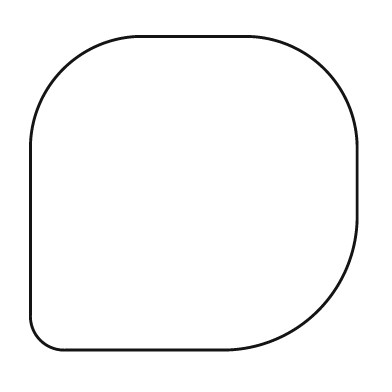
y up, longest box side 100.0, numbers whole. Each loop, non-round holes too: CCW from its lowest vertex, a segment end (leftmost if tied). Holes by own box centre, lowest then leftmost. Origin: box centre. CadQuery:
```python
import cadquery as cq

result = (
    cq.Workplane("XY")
    .moveTo(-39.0, -48.0)
    .lineTo(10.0, -48.0)
    .threePointArc((38.0, -36.0), (50.0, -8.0))
    .lineTo(50.0, 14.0)
    .threePointArc((40.0, 38.0), (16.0, 48.0))
    .lineTo(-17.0, 48.0)
    .threePointArc((-40.0, 38.0), (-50.0, 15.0))
    .lineTo(-50.0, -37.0)
    .threePointArc((-47.0, -45.0), (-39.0, -48.0))
    .close()
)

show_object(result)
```